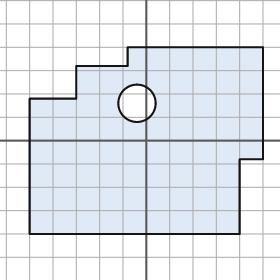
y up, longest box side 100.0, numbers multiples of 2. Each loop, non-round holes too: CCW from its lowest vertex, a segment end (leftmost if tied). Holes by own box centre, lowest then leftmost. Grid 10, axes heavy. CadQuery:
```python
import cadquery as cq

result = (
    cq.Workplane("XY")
    .moveTo(-50.0, -40.0)
    .lineTo(40.0, -40.0)
    .lineTo(40.0, -8.0)
    .lineTo(50.0, -8.0)
    .lineTo(50.0, 40.0)
    .lineTo(-8.0, 40.0)
    .lineTo(-8.0, 32.0)
    .lineTo(-30.0, 32.0)
    .lineTo(-30.0, 18.0)
    .lineTo(-50.0, 18.0)
    .close()
    .moveTo(-4.0, 16.0)
    .circle(8.0)
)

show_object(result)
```